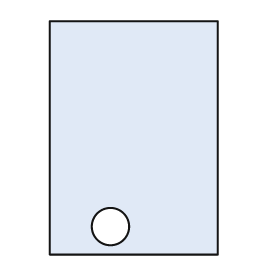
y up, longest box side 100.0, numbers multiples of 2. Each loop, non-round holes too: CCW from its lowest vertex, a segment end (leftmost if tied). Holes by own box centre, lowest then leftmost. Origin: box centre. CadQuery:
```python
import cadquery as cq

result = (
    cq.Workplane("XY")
    .moveTo(-36.0, -50.0)
    .lineTo(36.0, -50.0)
    .lineTo(36.0, 50.0)
    .lineTo(-36.0, 50.0)
    .close()
    .moveTo(-10.0, -38.0)
    .circle(8.0)
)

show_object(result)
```